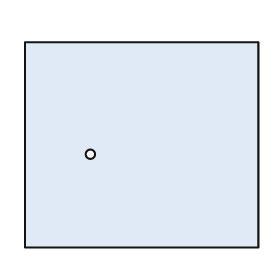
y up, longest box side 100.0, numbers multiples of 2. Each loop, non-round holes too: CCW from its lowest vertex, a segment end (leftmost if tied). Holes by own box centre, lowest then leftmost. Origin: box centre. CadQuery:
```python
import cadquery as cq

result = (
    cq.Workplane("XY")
    .moveTo(-50.0, -44.0)
    .lineTo(50.0, -44.0)
    .lineTo(50.0, 44.0)
    .lineTo(-50.0, 44.0)
    .close()
    .moveTo(-22.0, -4.0)
    .circle(2.0)
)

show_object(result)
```